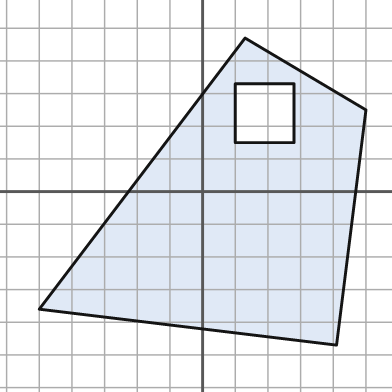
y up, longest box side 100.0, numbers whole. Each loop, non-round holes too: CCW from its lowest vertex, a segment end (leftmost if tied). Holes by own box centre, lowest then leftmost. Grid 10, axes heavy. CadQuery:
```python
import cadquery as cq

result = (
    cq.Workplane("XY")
    .moveTo(41.0, -47.0)
    .lineTo(50.0, 25.0)
    .lineTo(13.0, 47.0)
    .lineTo(-50.0, -36.0)
    .close()
    .moveTo(10.0, 15.0)
    .lineTo(28.0, 15.0)
    .lineTo(28.0, 33.0)
    .lineTo(10.0, 33.0)
    .close()
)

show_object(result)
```